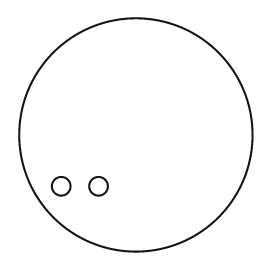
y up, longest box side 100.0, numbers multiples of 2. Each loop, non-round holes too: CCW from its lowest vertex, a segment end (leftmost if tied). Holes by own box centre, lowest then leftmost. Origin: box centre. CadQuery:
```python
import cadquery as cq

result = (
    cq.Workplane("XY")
    .moveTo(0.0, 0.0)
    .circle(50.0)
    .moveTo(-32.0, -22.0)
    .circle(4.0)
    .moveTo(-16.0, -22.0)
    .circle(4.0)
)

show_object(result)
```